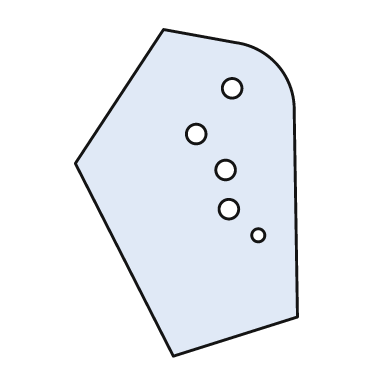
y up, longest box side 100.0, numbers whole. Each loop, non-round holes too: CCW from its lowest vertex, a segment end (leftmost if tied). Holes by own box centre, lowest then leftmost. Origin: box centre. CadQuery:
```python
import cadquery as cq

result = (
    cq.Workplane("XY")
    .moveTo(-4.0, -50.0)
    .lineTo(34.0, -38.0)
    .lineTo(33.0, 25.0)
    .threePointArc((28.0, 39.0), (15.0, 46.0))
    .lineTo(-7.0, 50.0)
    .lineTo(-34.0, 9.0)
    .close()
    .moveTo(22.0, -13.0)
    .circle(2.0)
    .moveTo(13.0, -5.0)
    .circle(3.0)
    .moveTo(12.0, 7.0)
    .circle(3.0)
    .moveTo(3.0, 18.0)
    .circle(3.0)
    .moveTo(14.0, 32.0)
    .circle(3.0)
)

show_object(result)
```